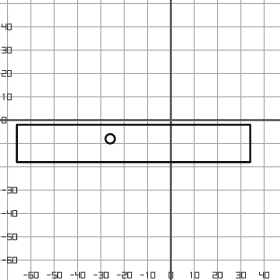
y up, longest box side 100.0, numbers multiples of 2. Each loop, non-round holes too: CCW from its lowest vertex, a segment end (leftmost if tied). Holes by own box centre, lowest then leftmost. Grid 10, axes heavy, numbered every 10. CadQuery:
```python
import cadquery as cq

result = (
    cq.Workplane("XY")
    .moveTo(-66.0, -18.0)
    .lineTo(34.0, -18.0)
    .lineTo(34.0, -2.0)
    .lineTo(-66.0, -2.0)
    .close()
    .moveTo(-26.0, -8.0)
    .circle(2.0)
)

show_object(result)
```